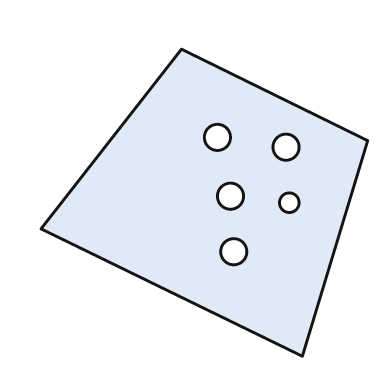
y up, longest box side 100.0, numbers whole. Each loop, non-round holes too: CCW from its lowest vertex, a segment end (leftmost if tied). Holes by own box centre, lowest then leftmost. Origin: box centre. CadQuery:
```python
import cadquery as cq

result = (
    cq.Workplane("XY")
    .moveTo(30.0, -47.0)
    .lineTo(50.0, 19.0)
    .lineTo(-7.0, 47.0)
    .lineTo(-50.0, -8.0)
    .close()
    .moveTo(9.0, -15.0)
    .circle(4.0)
    .moveTo(26.0, 0.0)
    .circle(3.0)
    .moveTo(8.0, 2.0)
    .circle(4.0)
    .moveTo(25.0, 17.0)
    .circle(4.0)
    .moveTo(4.0, 20.0)
    .circle(4.0)
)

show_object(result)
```